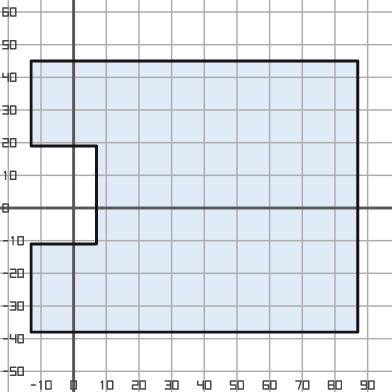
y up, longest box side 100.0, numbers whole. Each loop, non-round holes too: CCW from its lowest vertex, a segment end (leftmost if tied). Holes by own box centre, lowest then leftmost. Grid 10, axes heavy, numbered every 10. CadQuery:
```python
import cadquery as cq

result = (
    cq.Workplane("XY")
    .moveTo(-13.0, -38.0)
    .lineTo(87.0, -38.0)
    .lineTo(87.0, 45.0)
    .lineTo(-13.0, 45.0)
    .lineTo(-13.0, 19.0)
    .lineTo(7.0, 19.0)
    .lineTo(7.0, -11.0)
    .lineTo(-13.0, -11.0)
    .close()
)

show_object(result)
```